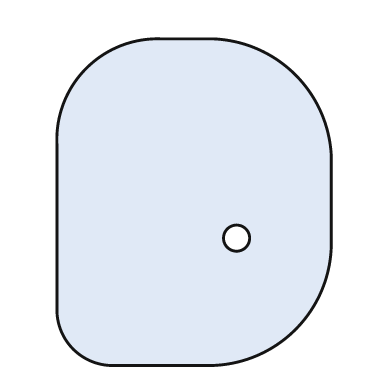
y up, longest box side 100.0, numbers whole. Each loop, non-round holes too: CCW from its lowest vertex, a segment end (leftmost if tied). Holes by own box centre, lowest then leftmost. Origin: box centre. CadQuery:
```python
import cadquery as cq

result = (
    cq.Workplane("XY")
    .moveTo(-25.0, -50.0)
    .lineTo(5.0, -50.0)
    .threePointArc((31.0, -39.0), (42.0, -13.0))
    .lineTo(42.0, 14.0)
    .threePointArc((31.0, 39.0), (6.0, 50.0))
    .lineTo(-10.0, 50.0)
    .threePointArc((-33.0, 41.0), (-42.0, 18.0))
    .lineTo(-42.0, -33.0)
    .threePointArc((-37.0, -45.0), (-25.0, -50.0))
    .close()
    .moveTo(13.0, -11.0)
    .circle(4.0)
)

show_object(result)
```